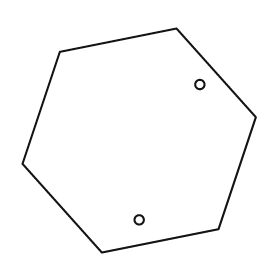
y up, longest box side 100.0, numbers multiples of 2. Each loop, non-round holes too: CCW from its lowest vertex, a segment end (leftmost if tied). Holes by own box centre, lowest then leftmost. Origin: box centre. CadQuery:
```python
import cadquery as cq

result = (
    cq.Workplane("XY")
    .moveTo(-16.0, -48.0)
    .lineTo(34.0, -38.0)
    .lineTo(50.0, 10.0)
    .lineTo(16.0, 48.0)
    .lineTo(-34.0, 38.0)
    .lineTo(-50.0, -10.0)
    .close()
    .moveTo(0.0, -34.0)
    .circle(2.0)
    .moveTo(26.0, 24.0)
    .circle(2.0)
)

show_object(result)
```